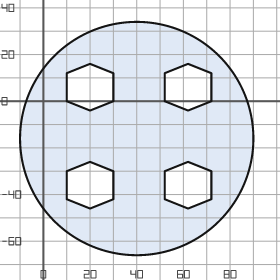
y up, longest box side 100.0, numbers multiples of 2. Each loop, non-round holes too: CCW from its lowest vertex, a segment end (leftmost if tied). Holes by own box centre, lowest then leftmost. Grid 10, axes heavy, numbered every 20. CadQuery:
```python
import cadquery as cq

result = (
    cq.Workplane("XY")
    .moveTo(40.0, -16.0)
    .circle(50.0)
    .moveTo(20.0, -46.0)
    .lineTo(30.0, -42.0)
    .lineTo(30.0, -30.0)
    .lineTo(20.0, -26.0)
    .lineTo(10.0, -30.0)
    .lineTo(10.0, -42.0)
    .close()
    .moveTo(62.0, -46.0)
    .lineTo(72.0, -42.0)
    .lineTo(72.0, -30.0)
    .lineTo(62.0, -26.0)
    .lineTo(52.0, -30.0)
    .lineTo(52.0, -42.0)
    .close()
    .moveTo(20.0, -4.0)
    .lineTo(30.0, 0.0)
    .lineTo(30.0, 12.0)
    .lineTo(20.0, 16.0)
    .lineTo(10.0, 12.0)
    .lineTo(10.0, 0.0)
    .close()
    .moveTo(62.0, -4.0)
    .lineTo(72.0, 0.0)
    .lineTo(72.0, 12.0)
    .lineTo(62.0, 16.0)
    .lineTo(52.0, 12.0)
    .lineTo(52.0, 0.0)
    .close()
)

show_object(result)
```